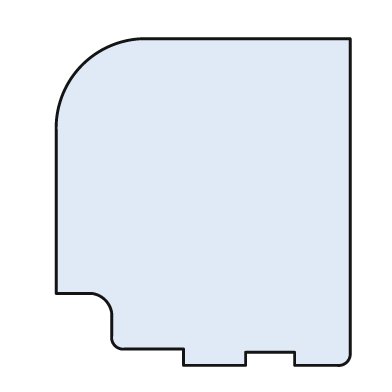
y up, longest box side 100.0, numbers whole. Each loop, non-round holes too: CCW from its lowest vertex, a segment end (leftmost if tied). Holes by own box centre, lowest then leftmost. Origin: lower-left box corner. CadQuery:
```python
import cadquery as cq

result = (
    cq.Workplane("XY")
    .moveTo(39.0, 0.0)
    .lineTo(58.0, 0.0)
    .lineTo(58.0, 4.0)
    .lineTo(73.0, 4.0)
    .lineTo(73.0, 0.0)
    .lineTo(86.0, 0.0)
    .threePointArc((89.0, 1.0), (90.0, 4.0))
    .lineTo(90.0, 100.0)
    .lineTo(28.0, 100.0)
    .threePointArc((8.0, 92.0), (0.0, 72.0))
    .lineTo(0.0, 22.0)
    .lineTo(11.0, 22.0)
    .threePointArc((15.0, 20.0), (17.0, 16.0))
    .lineTo(17.0, 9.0)
    .threePointArc((18.0, 6.0), (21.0, 5.0))
    .lineTo(39.0, 5.0)
    .close()
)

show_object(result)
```